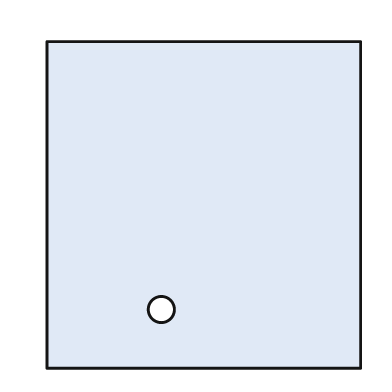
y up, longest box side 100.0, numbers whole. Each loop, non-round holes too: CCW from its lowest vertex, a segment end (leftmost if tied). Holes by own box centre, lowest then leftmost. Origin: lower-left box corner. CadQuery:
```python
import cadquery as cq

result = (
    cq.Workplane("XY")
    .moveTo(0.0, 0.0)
    .lineTo(96.0, 0.0)
    .lineTo(96.0, 100.0)
    .lineTo(0.0, 100.0)
    .close()
    .moveTo(35.0, 18.0)
    .circle(4.0)
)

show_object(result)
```